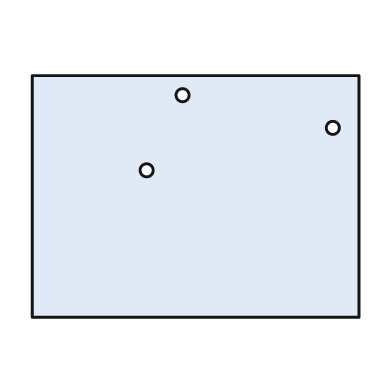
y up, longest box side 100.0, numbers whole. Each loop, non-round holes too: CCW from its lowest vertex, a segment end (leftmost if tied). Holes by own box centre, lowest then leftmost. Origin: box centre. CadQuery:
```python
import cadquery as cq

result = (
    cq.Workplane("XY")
    .moveTo(-50.0, -37.0)
    .lineTo(50.0, -37.0)
    .lineTo(50.0, 37.0)
    .lineTo(-50.0, 37.0)
    .close()
    .moveTo(-15.0, 8.0)
    .circle(2.0)
    .moveTo(42.0, 21.0)
    .circle(2.0)
    .moveTo(-4.0, 31.0)
    .circle(2.0)
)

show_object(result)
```